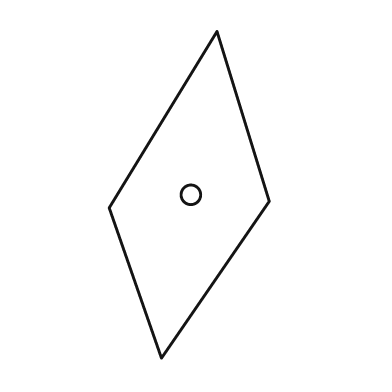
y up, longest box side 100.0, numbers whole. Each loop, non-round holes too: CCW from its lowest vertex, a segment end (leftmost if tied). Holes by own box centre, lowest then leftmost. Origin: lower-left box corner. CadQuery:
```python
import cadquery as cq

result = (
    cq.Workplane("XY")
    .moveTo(16.0, 0.0)
    .lineTo(49.0, 48.0)
    .lineTo(33.0, 100.0)
    .lineTo(0.0, 46.0)
    .close()
    .moveTo(25.0, 50.0)
    .circle(3.0)
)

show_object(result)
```